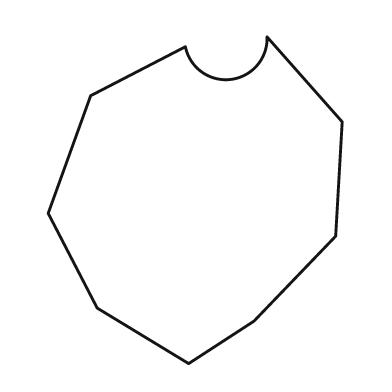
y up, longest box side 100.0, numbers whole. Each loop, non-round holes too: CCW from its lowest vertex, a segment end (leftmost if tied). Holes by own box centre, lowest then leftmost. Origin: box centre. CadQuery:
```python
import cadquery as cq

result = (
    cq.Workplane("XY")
    .moveTo(-2.0, -50.0)
    .lineTo(18.0, -37.0)
    .lineTo(43.0, -11.0)
    .lineTo(45.0, 24.0)
    .lineTo(22.0, 50.0)
    .threePointArc((11.0, 37.0), (-3.0, 47.0))
    .lineTo(-32.0, 32.0)
    .lineTo(-45.0, -4.0)
    .lineTo(-30.0, -33.0)
    .close()
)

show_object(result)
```